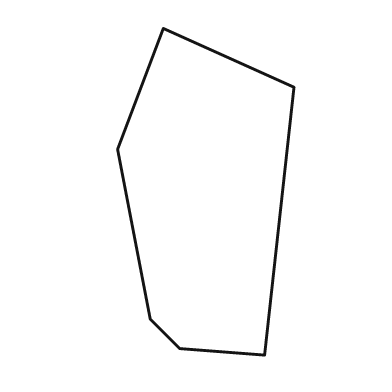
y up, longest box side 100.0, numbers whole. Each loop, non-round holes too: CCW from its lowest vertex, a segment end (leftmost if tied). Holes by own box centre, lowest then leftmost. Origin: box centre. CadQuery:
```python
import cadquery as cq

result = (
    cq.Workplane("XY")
    .moveTo(18.0, -50.0)
    .lineTo(27.0, 32.0)
    .lineTo(-13.0, 50.0)
    .lineTo(-27.0, 13.0)
    .lineTo(-17.0, -39.0)
    .lineTo(-8.0, -48.0)
    .close()
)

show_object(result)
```